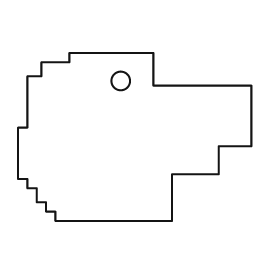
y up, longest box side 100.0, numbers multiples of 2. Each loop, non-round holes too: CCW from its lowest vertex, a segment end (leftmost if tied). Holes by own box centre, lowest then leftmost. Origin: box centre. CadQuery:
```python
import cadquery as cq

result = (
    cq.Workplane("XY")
    .moveTo(-34.0, -36.0)
    .lineTo(16.0, -36.0)
    .lineTo(16.0, -16.0)
    .lineTo(36.0, -16.0)
    .lineTo(36.0, -4.0)
    .lineTo(50.0, -4.0)
    .lineTo(50.0, 22.0)
    .lineTo(8.0, 22.0)
    .lineTo(8.0, 36.0)
    .lineTo(-28.0, 36.0)
    .lineTo(-28.0, 32.0)
    .lineTo(-40.0, 32.0)
    .lineTo(-40.0, 26.0)
    .lineTo(-46.0, 26.0)
    .lineTo(-46.0, 4.0)
    .lineTo(-50.0, 4.0)
    .lineTo(-50.0, -18.0)
    .lineTo(-46.0, -18.0)
    .lineTo(-46.0, -22.0)
    .lineTo(-42.0, -22.0)
    .lineTo(-42.0, -28.0)
    .lineTo(-38.0, -28.0)
    .lineTo(-38.0, -32.0)
    .lineTo(-34.0, -32.0)
    .close()
    .moveTo(-6.0, 24.0)
    .circle(4.0)
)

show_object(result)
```